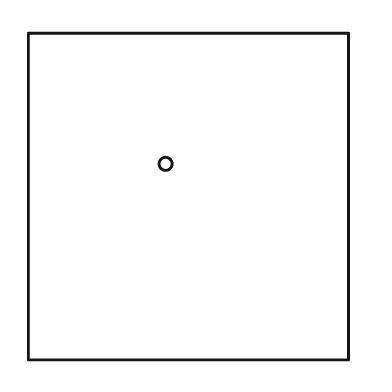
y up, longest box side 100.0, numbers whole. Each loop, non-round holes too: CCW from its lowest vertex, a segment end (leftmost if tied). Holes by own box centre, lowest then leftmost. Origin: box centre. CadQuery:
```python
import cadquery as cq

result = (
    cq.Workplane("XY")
    .moveTo(-49.0, -50.0)
    .lineTo(49.0, -50.0)
    .lineTo(49.0, 50.0)
    .lineTo(-49.0, 50.0)
    .close()
    .moveTo(-7.0, 10.0)
    .circle(2.0)
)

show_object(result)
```